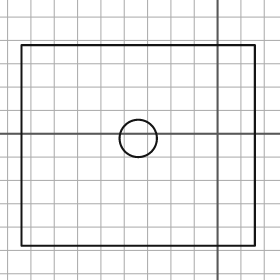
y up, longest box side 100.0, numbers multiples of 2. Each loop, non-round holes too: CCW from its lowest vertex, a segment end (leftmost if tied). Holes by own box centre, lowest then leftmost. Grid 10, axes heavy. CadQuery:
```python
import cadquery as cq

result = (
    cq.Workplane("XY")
    .moveTo(-84.0, -48.0)
    .lineTo(16.0, -48.0)
    .lineTo(16.0, 38.0)
    .lineTo(-84.0, 38.0)
    .close()
    .moveTo(-34.0, -2.0)
    .circle(8.0)
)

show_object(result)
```